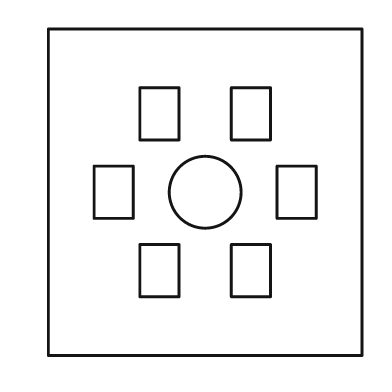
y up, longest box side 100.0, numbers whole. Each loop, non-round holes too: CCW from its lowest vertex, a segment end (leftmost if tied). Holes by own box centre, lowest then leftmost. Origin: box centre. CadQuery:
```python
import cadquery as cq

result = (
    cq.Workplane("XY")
    .moveTo(-48.0, -50.0)
    .lineTo(48.0, -50.0)
    .lineTo(48.0, 50.0)
    .lineTo(-48.0, 50.0)
    .close()
    .moveTo(-20.0, -32.0)
    .lineTo(-8.0, -32.0)
    .lineTo(-8.0, -16.0)
    .lineTo(-20.0, -16.0)
    .close()
    .moveTo(8.0, -32.0)
    .lineTo(20.0, -32.0)
    .lineTo(20.0, -16.0)
    .lineTo(8.0, -16.0)
    .close()
    .moveTo(-34.0, -8.0)
    .lineTo(-22.0, -8.0)
    .lineTo(-22.0, 8.0)
    .lineTo(-34.0, 8.0)
    .close()
    .moveTo(0.0, 0.0)
    .circle(11.0)
    .moveTo(22.0, -8.0)
    .lineTo(34.0, -8.0)
    .lineTo(34.0, 8.0)
    .lineTo(22.0, 8.0)
    .close()
    .moveTo(-20.0, 16.0)
    .lineTo(-8.0, 16.0)
    .lineTo(-8.0, 32.0)
    .lineTo(-20.0, 32.0)
    .close()
    .moveTo(8.0, 16.0)
    .lineTo(20.0, 16.0)
    .lineTo(20.0, 32.0)
    .lineTo(8.0, 32.0)
    .close()
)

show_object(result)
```